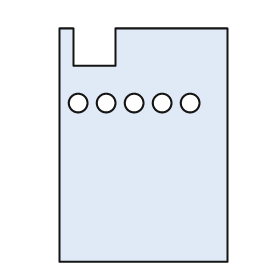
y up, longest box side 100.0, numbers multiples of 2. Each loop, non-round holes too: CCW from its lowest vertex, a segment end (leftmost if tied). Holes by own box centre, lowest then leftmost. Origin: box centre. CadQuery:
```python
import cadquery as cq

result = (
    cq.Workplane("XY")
    .moveTo(-36.0, -50.0)
    .lineTo(36.0, -50.0)
    .lineTo(36.0, 50.0)
    .lineTo(-12.0, 50.0)
    .lineTo(-12.0, 34.0)
    .lineTo(-30.0, 34.0)
    .lineTo(-30.0, 50.0)
    .lineTo(-36.0, 50.0)
    .close()
    .moveTo(-28.0, 18.0)
    .circle(4.0)
    .moveTo(-16.0, 18.0)
    .circle(4.0)
    .moveTo(-4.0, 18.0)
    .circle(4.0)
    .moveTo(8.0, 18.0)
    .circle(4.0)
    .moveTo(20.0, 18.0)
    .circle(4.0)
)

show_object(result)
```